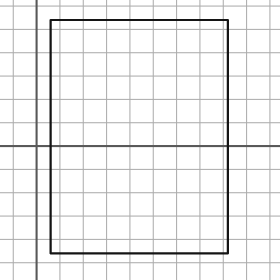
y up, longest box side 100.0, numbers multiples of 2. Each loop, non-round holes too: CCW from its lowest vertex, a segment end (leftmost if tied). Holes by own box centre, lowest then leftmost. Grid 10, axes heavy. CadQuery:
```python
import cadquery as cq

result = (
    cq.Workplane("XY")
    .moveTo(6.0, -46.0)
    .lineTo(82.0, -46.0)
    .lineTo(82.0, 54.0)
    .lineTo(6.0, 54.0)
    .close()
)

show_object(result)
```